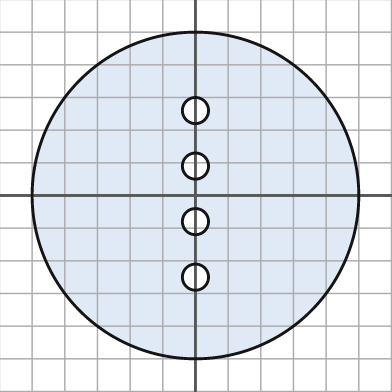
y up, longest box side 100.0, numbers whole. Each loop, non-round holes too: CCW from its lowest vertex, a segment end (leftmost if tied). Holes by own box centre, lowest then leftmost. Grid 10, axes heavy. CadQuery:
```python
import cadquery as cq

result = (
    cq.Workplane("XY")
    .moveTo(0.0, 0.0)
    .circle(50.0)
    .moveTo(0.0, -25.0)
    .circle(4.0)
    .moveTo(0.0, -8.0)
    .circle(4.0)
    .moveTo(0.0, 9.0)
    .circle(4.0)
    .moveTo(0.0, 26.0)
    .circle(4.0)
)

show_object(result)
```